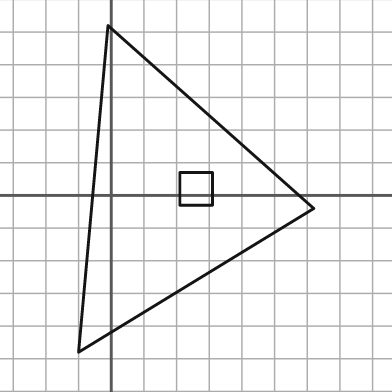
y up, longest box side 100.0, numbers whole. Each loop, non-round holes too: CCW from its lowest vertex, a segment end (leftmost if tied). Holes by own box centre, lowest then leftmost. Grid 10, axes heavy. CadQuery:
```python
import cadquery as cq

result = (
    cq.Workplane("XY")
    .moveTo(-10.0, -48.0)
    .lineTo(62.0, -4.0)
    .lineTo(-1.0, 52.0)
    .close()
    .moveTo(21.0, -3.0)
    .lineTo(31.0, -3.0)
    .lineTo(31.0, 7.0)
    .lineTo(21.0, 7.0)
    .close()
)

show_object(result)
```